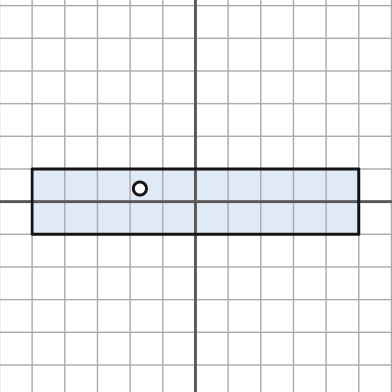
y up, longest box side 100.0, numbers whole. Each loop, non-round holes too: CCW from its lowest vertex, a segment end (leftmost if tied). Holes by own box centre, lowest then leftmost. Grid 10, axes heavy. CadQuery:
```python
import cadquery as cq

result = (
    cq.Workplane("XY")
    .moveTo(-50.0, -10.0)
    .lineTo(50.0, -10.0)
    .lineTo(50.0, 10.0)
    .lineTo(-50.0, 10.0)
    .close()
    .moveTo(-17.0, 4.0)
    .circle(2.0)
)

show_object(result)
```